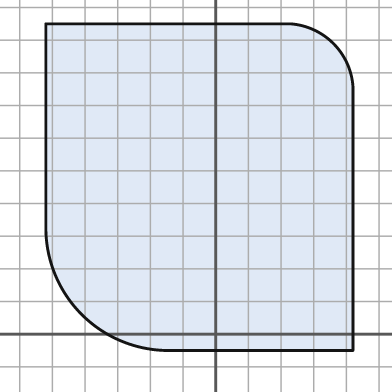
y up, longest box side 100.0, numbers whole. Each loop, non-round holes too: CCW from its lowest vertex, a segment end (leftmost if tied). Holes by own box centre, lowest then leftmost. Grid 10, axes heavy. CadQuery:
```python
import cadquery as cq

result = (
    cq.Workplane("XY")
    .moveTo(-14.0, -5.0)
    .lineTo(42.0, -5.0)
    .lineTo(42.0, 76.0)
    .threePointArc((36.0, 89.0), (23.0, 95.0))
    .lineTo(-52.0, 95.0)
    .lineTo(-52.0, 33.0)
    .threePointArc((-41.0, 6.0), (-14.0, -5.0))
    .close()
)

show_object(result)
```